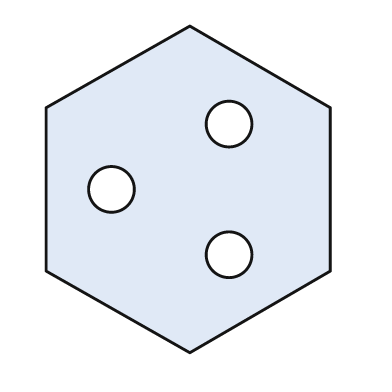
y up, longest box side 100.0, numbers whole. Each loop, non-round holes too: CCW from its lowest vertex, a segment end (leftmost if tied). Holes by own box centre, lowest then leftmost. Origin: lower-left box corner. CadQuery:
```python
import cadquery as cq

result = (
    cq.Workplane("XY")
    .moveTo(44.0, 0.0)
    .lineTo(87.0, 25.0)
    .lineTo(87.0, 75.0)
    .lineTo(44.0, 100.0)
    .lineTo(0.0, 75.0)
    .lineTo(0.0, 25.0)
    .close()
    .moveTo(56.0, 30.0)
    .circle(7.0)
    .moveTo(20.0, 50.0)
    .circle(7.0)
    .moveTo(56.0, 70.0)
    .circle(7.0)
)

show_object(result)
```